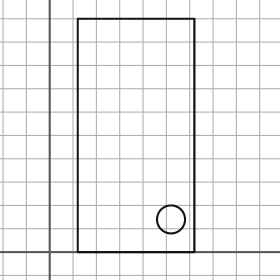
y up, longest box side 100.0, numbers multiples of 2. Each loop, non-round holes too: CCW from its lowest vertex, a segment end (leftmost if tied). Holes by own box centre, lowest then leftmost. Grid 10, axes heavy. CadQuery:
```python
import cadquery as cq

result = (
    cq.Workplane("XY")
    .moveTo(12.0, 0.0)
    .lineTo(62.0, 0.0)
    .lineTo(62.0, 100.0)
    .lineTo(12.0, 100.0)
    .close()
    .moveTo(52.0, 14.0)
    .circle(6.0)
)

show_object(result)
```